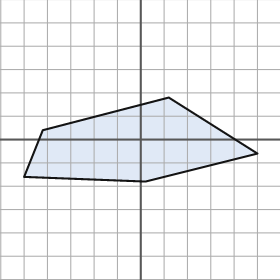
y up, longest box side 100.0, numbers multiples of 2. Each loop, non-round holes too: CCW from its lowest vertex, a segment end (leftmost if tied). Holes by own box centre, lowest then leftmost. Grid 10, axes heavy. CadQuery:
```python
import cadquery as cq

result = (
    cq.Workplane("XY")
    .moveTo(2.0, -18.0)
    .lineTo(50.0, -6.0)
    .lineTo(12.0, 18.0)
    .lineTo(-42.0, 4.0)
    .lineTo(-50.0, -16.0)
    .close()
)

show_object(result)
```